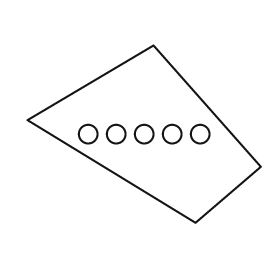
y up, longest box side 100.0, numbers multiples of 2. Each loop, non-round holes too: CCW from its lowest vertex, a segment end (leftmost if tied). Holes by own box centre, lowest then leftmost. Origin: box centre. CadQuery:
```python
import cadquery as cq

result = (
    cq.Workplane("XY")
    .moveTo(22.0, -38.0)
    .lineTo(50.0, -14.0)
    .lineTo(4.0, 38.0)
    .lineTo(-50.0, 6.0)
    .close()
    .moveTo(-24.0, 0.0)
    .circle(4.0)
    .moveTo(-12.0, 0.0)
    .circle(4.0)
    .moveTo(0.0, 0.0)
    .circle(4.0)
    .moveTo(12.0, 0.0)
    .circle(4.0)
    .moveTo(24.0, 0.0)
    .circle(4.0)
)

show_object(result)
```